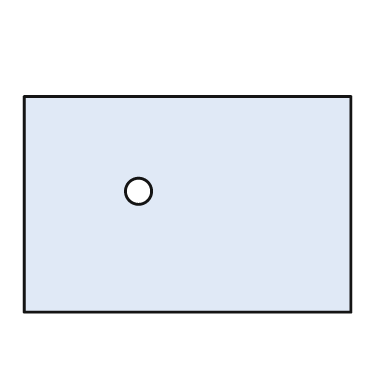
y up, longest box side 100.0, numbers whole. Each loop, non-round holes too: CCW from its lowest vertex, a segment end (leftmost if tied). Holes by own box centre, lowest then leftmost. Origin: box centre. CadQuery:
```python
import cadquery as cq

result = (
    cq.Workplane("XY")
    .moveTo(-50.0, -33.0)
    .lineTo(50.0, -33.0)
    .lineTo(50.0, 33.0)
    .lineTo(-50.0, 33.0)
    .close()
    .moveTo(-15.0, 4.0)
    .circle(4.0)
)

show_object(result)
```